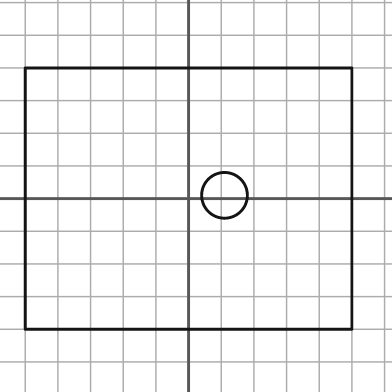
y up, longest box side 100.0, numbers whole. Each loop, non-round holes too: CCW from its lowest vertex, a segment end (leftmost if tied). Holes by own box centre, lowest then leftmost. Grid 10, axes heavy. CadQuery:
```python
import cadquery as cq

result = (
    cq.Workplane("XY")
    .moveTo(-50.0, -40.0)
    .lineTo(50.0, -40.0)
    .lineTo(50.0, 40.0)
    .lineTo(-50.0, 40.0)
    .close()
    .moveTo(11.0, 1.0)
    .circle(7.0)
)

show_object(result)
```